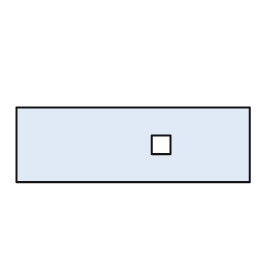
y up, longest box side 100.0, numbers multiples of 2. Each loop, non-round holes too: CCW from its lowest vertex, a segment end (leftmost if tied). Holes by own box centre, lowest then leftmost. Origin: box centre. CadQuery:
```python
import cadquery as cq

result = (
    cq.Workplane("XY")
    .moveTo(-50.0, -16.0)
    .lineTo(50.0, -16.0)
    .lineTo(50.0, 16.0)
    .lineTo(-50.0, 16.0)
    .close()
    .moveTo(8.0, -4.0)
    .lineTo(16.0, -4.0)
    .lineTo(16.0, 4.0)
    .lineTo(8.0, 4.0)
    .close()
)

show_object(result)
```